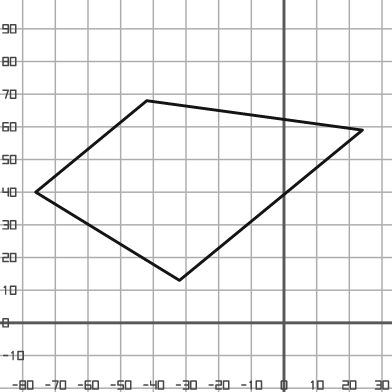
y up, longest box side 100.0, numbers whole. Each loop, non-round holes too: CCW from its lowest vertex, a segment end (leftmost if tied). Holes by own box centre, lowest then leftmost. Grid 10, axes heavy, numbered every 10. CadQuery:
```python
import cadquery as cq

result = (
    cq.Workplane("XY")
    .moveTo(-32.0, 13.0)
    .lineTo(24.0, 59.0)
    .lineTo(-42.0, 68.0)
    .lineTo(-76.0, 40.0)
    .close()
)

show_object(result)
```